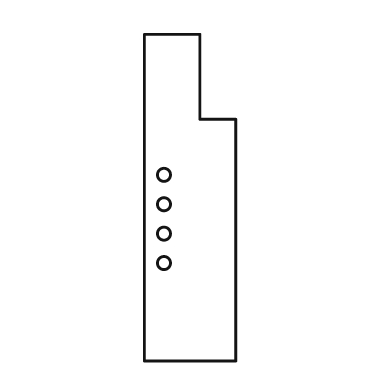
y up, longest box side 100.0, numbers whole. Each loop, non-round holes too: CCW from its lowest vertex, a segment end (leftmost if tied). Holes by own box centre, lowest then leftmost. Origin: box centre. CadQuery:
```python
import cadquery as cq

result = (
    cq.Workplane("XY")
    .moveTo(-14.0, -50.0)
    .lineTo(14.0, -50.0)
    .lineTo(14.0, 24.0)
    .lineTo(3.0, 24.0)
    .lineTo(3.0, 50.0)
    .lineTo(-14.0, 50.0)
    .close()
    .moveTo(-8.0, -20.0)
    .circle(2.0)
    .moveTo(-8.0, -11.0)
    .circle(2.0)
    .moveTo(-8.0, -2.0)
    .circle(2.0)
    .moveTo(-8.0, 7.0)
    .circle(2.0)
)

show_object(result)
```